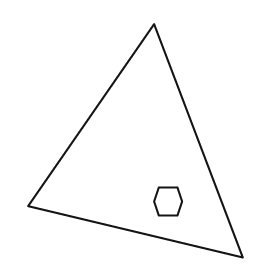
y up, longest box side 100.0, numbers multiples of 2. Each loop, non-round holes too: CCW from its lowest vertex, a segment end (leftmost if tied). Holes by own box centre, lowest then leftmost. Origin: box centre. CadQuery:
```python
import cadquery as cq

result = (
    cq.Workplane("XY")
    .moveTo(46.0, -50.0)
    .lineTo(8.0, 50.0)
    .lineTo(-46.0, -28.0)
    .close()
    .moveTo(10.0, -32.0)
    .lineTo(18.0, -32.0)
    .lineTo(20.0, -26.0)
    .lineTo(18.0, -20.0)
    .lineTo(10.0, -20.0)
    .lineTo(8.0, -26.0)
    .close()
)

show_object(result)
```